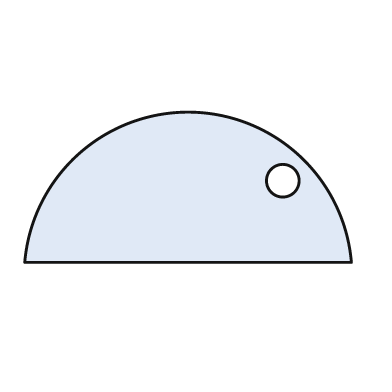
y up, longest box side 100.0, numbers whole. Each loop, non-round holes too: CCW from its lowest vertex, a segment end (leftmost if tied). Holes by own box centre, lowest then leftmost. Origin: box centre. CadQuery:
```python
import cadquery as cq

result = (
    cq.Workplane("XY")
    .moveTo(-50.0, -23.0)
    .lineTo(50.0, -23.0)
    .threePointArc((0.0, 23.0), (-50.0, -23.0))
    .close()
    .moveTo(29.0, 2.0)
    .circle(5.0)
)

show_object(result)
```